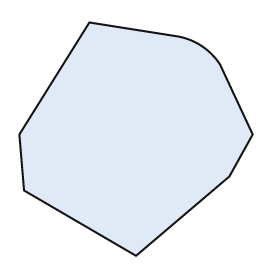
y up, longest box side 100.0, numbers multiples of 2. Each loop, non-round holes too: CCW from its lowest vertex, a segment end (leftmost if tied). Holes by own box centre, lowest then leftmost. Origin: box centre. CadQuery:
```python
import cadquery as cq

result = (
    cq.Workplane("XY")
    .moveTo(0.0, -50.0)
    .lineTo(40.0, -16.0)
    .lineTo(50.0, 2.0)
    .lineTo(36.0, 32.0)
    .threePointArc((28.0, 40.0), (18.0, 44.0))
    .lineTo(-20.0, 50.0)
    .lineTo(-50.0, 2.0)
    .lineTo(-48.0, -22.0)
    .close()
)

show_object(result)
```